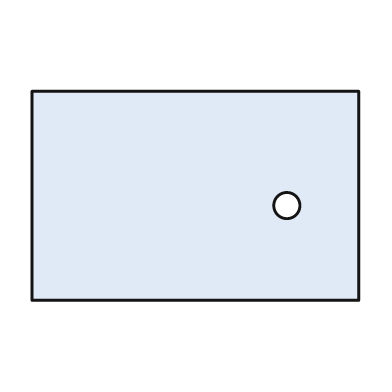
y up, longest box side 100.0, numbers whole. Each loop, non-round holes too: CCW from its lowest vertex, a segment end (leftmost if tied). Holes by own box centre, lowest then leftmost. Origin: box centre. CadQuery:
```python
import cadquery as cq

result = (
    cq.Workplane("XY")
    .moveTo(-50.0, -32.0)
    .lineTo(50.0, -32.0)
    .lineTo(50.0, 32.0)
    .lineTo(-50.0, 32.0)
    .close()
    .moveTo(28.0, -3.0)
    .circle(4.0)
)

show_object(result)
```